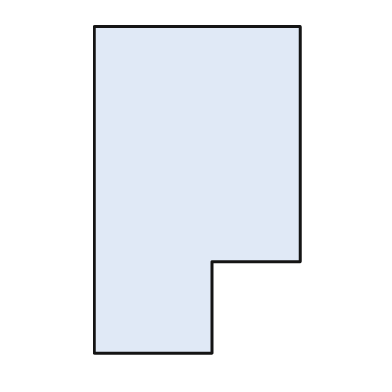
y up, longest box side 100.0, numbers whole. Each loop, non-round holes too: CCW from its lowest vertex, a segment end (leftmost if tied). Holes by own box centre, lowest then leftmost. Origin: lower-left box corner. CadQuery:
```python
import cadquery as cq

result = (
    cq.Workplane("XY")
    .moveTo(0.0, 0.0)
    .lineTo(36.0, 0.0)
    .lineTo(36.0, 28.0)
    .lineTo(63.0, 28.0)
    .lineTo(63.0, 100.0)
    .lineTo(0.0, 100.0)
    .close()
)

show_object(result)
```